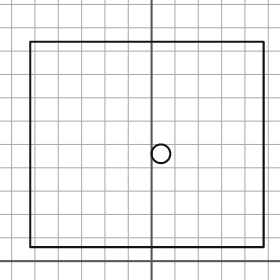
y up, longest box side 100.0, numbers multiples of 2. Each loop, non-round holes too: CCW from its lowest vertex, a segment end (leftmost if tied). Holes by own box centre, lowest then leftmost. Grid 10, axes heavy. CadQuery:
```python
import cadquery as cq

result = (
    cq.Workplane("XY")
    .moveTo(-52.0, 6.0)
    .lineTo(48.0, 6.0)
    .lineTo(48.0, 94.0)
    .lineTo(-52.0, 94.0)
    .close()
    .moveTo(4.0, 46.0)
    .circle(4.0)
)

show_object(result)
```